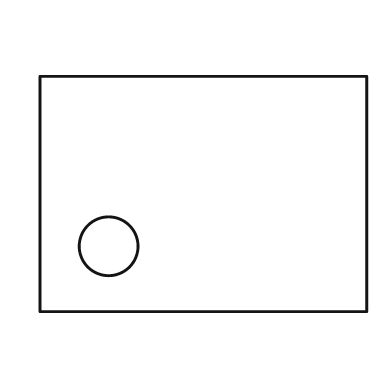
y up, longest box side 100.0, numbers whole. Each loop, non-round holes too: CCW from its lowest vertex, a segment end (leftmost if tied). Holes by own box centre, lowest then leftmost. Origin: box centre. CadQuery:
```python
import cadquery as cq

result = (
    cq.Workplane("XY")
    .moveTo(-50.0, -36.0)
    .lineTo(50.0, -36.0)
    .lineTo(50.0, 36.0)
    .lineTo(-50.0, 36.0)
    .close()
    .moveTo(-29.0, -16.0)
    .circle(9.0)
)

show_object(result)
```